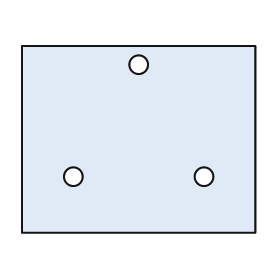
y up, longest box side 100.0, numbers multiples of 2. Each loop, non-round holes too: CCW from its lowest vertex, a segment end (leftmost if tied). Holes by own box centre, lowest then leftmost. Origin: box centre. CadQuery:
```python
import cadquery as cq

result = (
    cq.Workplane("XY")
    .moveTo(-50.0, -40.0)
    .lineTo(50.0, -40.0)
    .lineTo(50.0, 40.0)
    .lineTo(-50.0, 40.0)
    .close()
    .moveTo(-28.0, -16.0)
    .circle(4.0)
    .moveTo(28.0, -16.0)
    .circle(4.0)
    .moveTo(0.0, 32.0)
    .circle(4.0)
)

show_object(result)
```